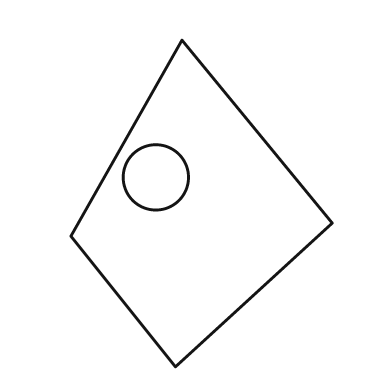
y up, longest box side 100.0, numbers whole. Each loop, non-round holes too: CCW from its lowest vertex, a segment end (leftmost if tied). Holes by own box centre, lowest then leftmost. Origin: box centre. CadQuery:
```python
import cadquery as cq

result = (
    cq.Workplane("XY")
    .moveTo(-8.0, -50.0)
    .lineTo(40.0, -6.0)
    .lineTo(-6.0, 50.0)
    .lineTo(-40.0, -10.0)
    .close()
    .moveTo(-14.0, 8.0)
    .circle(10.0)
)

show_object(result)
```